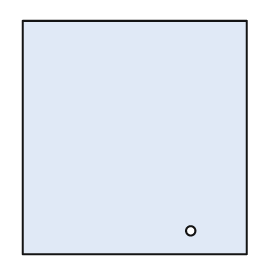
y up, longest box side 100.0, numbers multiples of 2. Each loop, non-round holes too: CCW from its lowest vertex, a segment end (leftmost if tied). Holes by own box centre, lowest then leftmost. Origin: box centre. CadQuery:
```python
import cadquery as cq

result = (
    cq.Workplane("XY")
    .moveTo(-48.0, -50.0)
    .lineTo(48.0, -50.0)
    .lineTo(48.0, 50.0)
    .lineTo(-48.0, 50.0)
    .close()
    .moveTo(24.0, -40.0)
    .circle(2.0)
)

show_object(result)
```